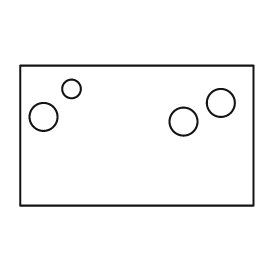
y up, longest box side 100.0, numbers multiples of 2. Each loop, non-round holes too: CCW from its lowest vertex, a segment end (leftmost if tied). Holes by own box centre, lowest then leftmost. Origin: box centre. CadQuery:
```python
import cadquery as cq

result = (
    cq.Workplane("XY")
    .moveTo(-50.0, -30.0)
    .lineTo(50.0, -30.0)
    .lineTo(50.0, 30.0)
    .lineTo(-50.0, 30.0)
    .close()
    .moveTo(20.0, 6.0)
    .circle(6.0)
    .moveTo(-40.0, 8.0)
    .circle(6.0)
    .moveTo(36.0, 14.0)
    .circle(6.0)
    .moveTo(-28.0, 20.0)
    .circle(4.0)
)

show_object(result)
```